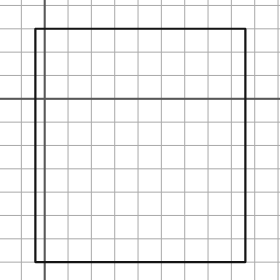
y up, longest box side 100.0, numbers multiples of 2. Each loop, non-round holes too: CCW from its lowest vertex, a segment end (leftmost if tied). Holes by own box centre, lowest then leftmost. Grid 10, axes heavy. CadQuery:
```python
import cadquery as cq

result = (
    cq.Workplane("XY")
    .moveTo(-4.0, -70.0)
    .lineTo(86.0, -70.0)
    .lineTo(86.0, 30.0)
    .lineTo(-4.0, 30.0)
    .close()
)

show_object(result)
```